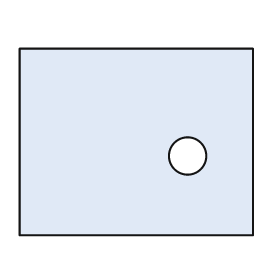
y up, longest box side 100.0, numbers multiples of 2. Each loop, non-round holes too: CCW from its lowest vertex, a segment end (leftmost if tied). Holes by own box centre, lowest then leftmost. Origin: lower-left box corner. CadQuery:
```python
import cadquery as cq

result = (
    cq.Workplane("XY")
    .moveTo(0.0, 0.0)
    .lineTo(100.0, 0.0)
    .lineTo(100.0, 80.0)
    .lineTo(0.0, 80.0)
    .close()
    .moveTo(72.0, 34.0)
    .circle(8.0)
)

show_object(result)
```